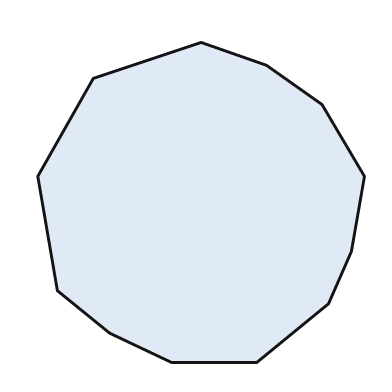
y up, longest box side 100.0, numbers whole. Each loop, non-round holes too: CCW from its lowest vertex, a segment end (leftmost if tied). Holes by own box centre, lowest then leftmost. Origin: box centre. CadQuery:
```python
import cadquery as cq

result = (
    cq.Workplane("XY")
    .moveTo(-9.0, -49.0)
    .lineTo(17.0, -49.0)
    .lineTo(39.0, -31.0)
    .lineTo(46.0, -15.0)
    .lineTo(50.0, 8.0)
    .lineTo(37.0, 30.0)
    .lineTo(20.0, 42.0)
    .lineTo(0.0, 49.0)
    .lineTo(-33.0, 38.0)
    .lineTo(-50.0, 8.0)
    .lineTo(-44.0, -27.0)
    .lineTo(-28.0, -40.0)
    .close()
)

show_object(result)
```